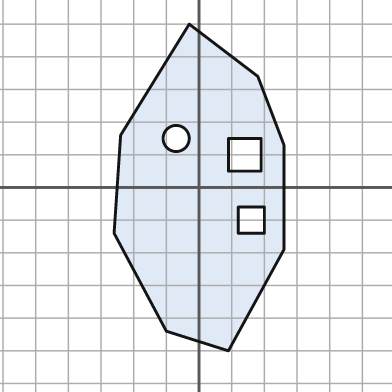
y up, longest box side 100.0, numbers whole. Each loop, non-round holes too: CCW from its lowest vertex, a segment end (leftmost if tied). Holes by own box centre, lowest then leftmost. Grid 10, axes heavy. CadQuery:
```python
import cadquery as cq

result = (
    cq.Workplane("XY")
    .moveTo(9.0, -50.0)
    .lineTo(26.0, -19.0)
    .lineTo(26.0, 13.0)
    .lineTo(18.0, 34.0)
    .lineTo(-3.0, 50.0)
    .lineTo(-24.0, 16.0)
    .lineTo(-26.0, -14.0)
    .lineTo(-10.0, -44.0)
    .close()
    .moveTo(12.0, -14.0)
    .lineTo(20.0, -14.0)
    .lineTo(20.0, -6.0)
    .lineTo(12.0, -6.0)
    .close()
    .moveTo(9.0, 5.0)
    .lineTo(19.0, 5.0)
    .lineTo(19.0, 15.0)
    .lineTo(9.0, 15.0)
    .close()
    .moveTo(-7.0, 15.0)
    .circle(4.0)
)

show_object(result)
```